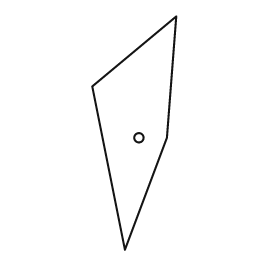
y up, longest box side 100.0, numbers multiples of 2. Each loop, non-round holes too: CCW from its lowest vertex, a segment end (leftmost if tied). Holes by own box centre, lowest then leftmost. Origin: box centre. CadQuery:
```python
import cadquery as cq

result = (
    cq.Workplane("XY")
    .moveTo(-4.0, -50.0)
    .lineTo(14.0, -2.0)
    .lineTo(18.0, 50.0)
    .lineTo(-18.0, 20.0)
    .close()
    .moveTo(2.0, -2.0)
    .circle(2.0)
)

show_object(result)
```